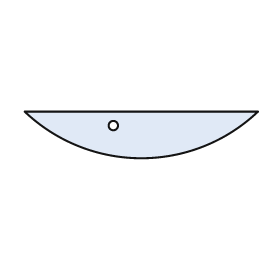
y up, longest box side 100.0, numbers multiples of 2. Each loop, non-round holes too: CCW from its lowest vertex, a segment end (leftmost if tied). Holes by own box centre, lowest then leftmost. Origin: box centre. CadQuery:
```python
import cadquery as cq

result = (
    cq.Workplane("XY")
    .moveTo(-50.0, 10.0)
    .threePointArc((0.0, -10.0), (50.0, 10.0))
    .close()
    .moveTo(-12.0, 4.0)
    .circle(2.0)
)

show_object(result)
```